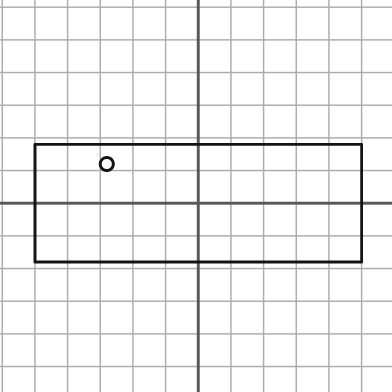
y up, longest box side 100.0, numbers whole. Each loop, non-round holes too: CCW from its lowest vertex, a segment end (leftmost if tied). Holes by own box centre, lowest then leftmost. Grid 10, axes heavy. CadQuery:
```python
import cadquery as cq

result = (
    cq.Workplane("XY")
    .moveTo(-50.0, -18.0)
    .lineTo(50.0, -18.0)
    .lineTo(50.0, 18.0)
    .lineTo(-50.0, 18.0)
    .close()
    .moveTo(-28.0, 12.0)
    .circle(2.0)
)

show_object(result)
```